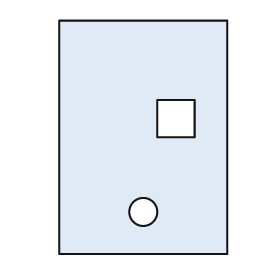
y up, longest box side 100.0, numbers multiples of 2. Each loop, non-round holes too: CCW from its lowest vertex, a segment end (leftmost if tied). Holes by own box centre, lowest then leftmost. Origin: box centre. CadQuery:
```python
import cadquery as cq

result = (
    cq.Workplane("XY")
    .moveTo(-36.0, -50.0)
    .lineTo(36.0, -50.0)
    .lineTo(36.0, 50.0)
    .lineTo(-36.0, 50.0)
    .close()
    .moveTo(0.0, -32.0)
    .circle(6.0)
    .moveTo(6.0, 0.0)
    .lineTo(22.0, 0.0)
    .lineTo(22.0, 16.0)
    .lineTo(6.0, 16.0)
    .close()
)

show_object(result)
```